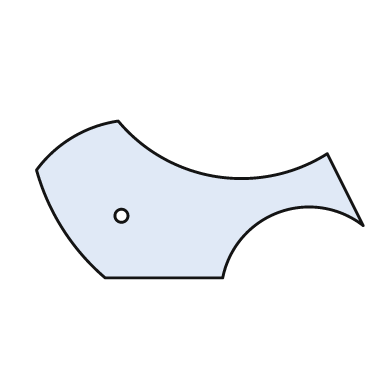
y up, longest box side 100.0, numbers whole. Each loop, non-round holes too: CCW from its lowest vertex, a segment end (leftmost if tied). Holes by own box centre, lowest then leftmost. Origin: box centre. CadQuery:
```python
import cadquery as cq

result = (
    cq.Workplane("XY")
    .moveTo(-29.0, -24.0)
    .lineTo(7.0, -24.0)
    .threePointArc((24.0, -4.0), (50.0, -8.0))
    .lineTo(39.0, 14.0)
    .threePointArc((5.0, 7.0), (-25.0, 24.0))
    .threePointArc((-39.0, 19.0), (-50.0, 9.0))
    .threePointArc((-42.0, -9.0), (-29.0, -24.0))
    .close()
    .moveTo(-24.0, -5.0)
    .circle(2.0)
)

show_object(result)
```